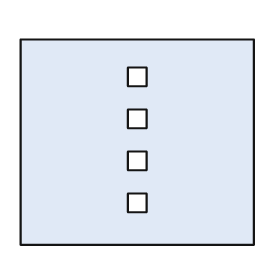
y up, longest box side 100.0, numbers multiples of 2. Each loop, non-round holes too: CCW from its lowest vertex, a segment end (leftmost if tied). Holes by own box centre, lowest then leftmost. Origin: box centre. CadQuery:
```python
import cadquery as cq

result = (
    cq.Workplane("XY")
    .moveTo(-50.0, -44.0)
    .lineTo(50.0, -44.0)
    .lineTo(50.0, 44.0)
    .lineTo(-50.0, 44.0)
    .close()
    .moveTo(-4.0, -30.0)
    .lineTo(4.0, -30.0)
    .lineTo(4.0, -22.0)
    .lineTo(-4.0, -22.0)
    .close()
    .moveTo(-4.0, -12.0)
    .lineTo(4.0, -12.0)
    .lineTo(4.0, -4.0)
    .lineTo(-4.0, -4.0)
    .close()
    .moveTo(-4.0, 6.0)
    .lineTo(4.0, 6.0)
    .lineTo(4.0, 14.0)
    .lineTo(-4.0, 14.0)
    .close()
    .moveTo(-4.0, 24.0)
    .lineTo(4.0, 24.0)
    .lineTo(4.0, 32.0)
    .lineTo(-4.0, 32.0)
    .close()
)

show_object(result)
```